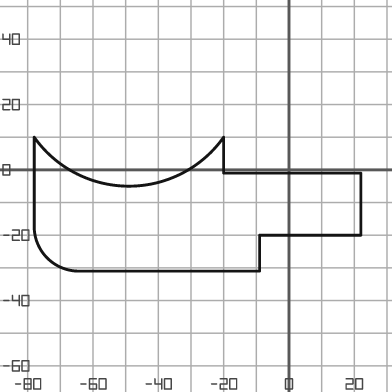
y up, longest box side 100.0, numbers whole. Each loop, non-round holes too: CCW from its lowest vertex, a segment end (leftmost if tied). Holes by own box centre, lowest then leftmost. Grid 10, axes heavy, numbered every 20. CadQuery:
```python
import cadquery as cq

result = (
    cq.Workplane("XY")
    .moveTo(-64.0, -31.0)
    .lineTo(-9.0, -31.0)
    .lineTo(-9.0, -20.0)
    .lineTo(22.0, -20.0)
    .lineTo(22.0, -1.0)
    .lineTo(-20.0, -1.0)
    .lineTo(-20.0, 10.0)
    .threePointArc((-49.0, -5.0), (-78.0, 10.0))
    .lineTo(-78.0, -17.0)
    .threePointArc((-74.0, -27.0), (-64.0, -31.0))
    .close()
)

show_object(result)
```